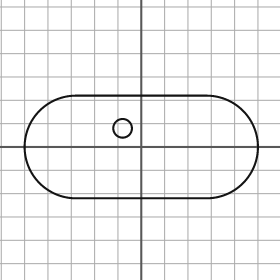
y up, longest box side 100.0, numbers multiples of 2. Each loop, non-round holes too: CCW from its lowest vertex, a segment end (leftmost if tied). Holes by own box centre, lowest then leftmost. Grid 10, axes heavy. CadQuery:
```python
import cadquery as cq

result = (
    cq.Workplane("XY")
    .moveTo(-28.0, -22.0)
    .lineTo(28.0, -22.0)
    .threePointArc((50.0, 0.0), (28.0, 22.0))
    .lineTo(-28.0, 22.0)
    .threePointArc((-50.0, 0.0), (-28.0, -22.0))
    .close()
    .moveTo(-8.0, 8.0)
    .circle(4.0)
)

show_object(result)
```